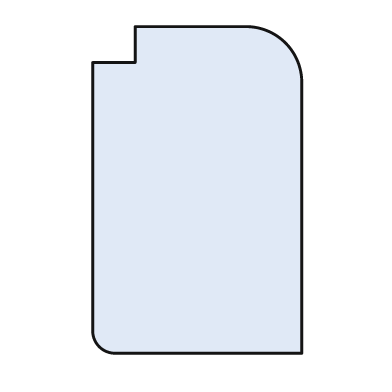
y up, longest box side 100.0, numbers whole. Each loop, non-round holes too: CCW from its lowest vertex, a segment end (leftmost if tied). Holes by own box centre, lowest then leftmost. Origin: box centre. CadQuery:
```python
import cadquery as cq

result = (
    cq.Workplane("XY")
    .moveTo(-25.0, -50.0)
    .lineTo(32.0, -50.0)
    .lineTo(32.0, 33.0)
    .threePointArc((27.0, 45.0), (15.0, 50.0))
    .lineTo(-19.0, 50.0)
    .lineTo(-19.0, 39.0)
    .lineTo(-32.0, 39.0)
    .lineTo(-32.0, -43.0)
    .threePointArc((-30.0, -48.0), (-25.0, -50.0))
    .close()
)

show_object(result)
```